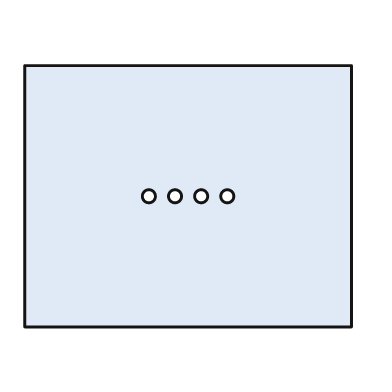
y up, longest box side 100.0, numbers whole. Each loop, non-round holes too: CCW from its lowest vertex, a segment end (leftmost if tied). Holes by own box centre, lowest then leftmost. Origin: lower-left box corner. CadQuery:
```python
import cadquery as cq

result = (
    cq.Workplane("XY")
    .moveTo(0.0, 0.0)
    .lineTo(100.0, 0.0)
    .lineTo(100.0, 80.0)
    .lineTo(0.0, 80.0)
    .close()
    .moveTo(38.0, 40.0)
    .circle(2.0)
    .moveTo(46.0, 40.0)
    .circle(2.0)
    .moveTo(54.0, 40.0)
    .circle(2.0)
    .moveTo(62.0, 40.0)
    .circle(2.0)
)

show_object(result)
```